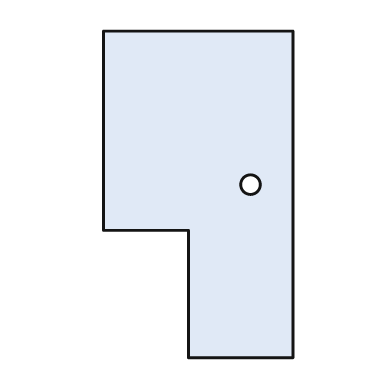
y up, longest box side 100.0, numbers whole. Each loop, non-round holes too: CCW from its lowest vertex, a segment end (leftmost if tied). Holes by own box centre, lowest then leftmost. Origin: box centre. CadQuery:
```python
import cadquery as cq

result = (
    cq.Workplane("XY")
    .moveTo(-3.0, -50.0)
    .lineTo(29.0, -50.0)
    .lineTo(29.0, 50.0)
    .lineTo(-29.0, 50.0)
    .lineTo(-29.0, -11.0)
    .lineTo(-3.0, -11.0)
    .close()
    .moveTo(16.0, 3.0)
    .circle(3.0)
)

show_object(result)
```